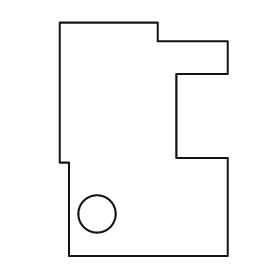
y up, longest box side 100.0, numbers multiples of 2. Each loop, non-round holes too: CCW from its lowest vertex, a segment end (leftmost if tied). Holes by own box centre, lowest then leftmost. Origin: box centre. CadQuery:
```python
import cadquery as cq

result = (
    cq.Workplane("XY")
    .moveTo(-32.0, -50.0)
    .lineTo(36.0, -50.0)
    .lineTo(36.0, -8.0)
    .lineTo(14.0, -8.0)
    .lineTo(14.0, 28.0)
    .lineTo(36.0, 28.0)
    .lineTo(36.0, 42.0)
    .lineTo(6.0, 42.0)
    .lineTo(6.0, 50.0)
    .lineTo(-36.0, 50.0)
    .lineTo(-36.0, -10.0)
    .lineTo(-32.0, -10.0)
    .close()
    .moveTo(-20.0, -32.0)
    .circle(8.0)
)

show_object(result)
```